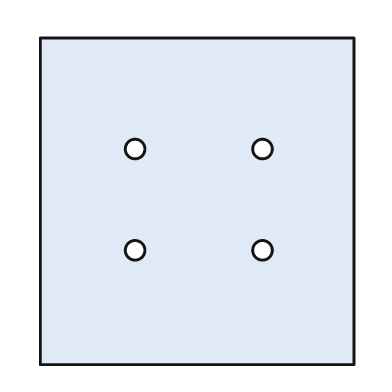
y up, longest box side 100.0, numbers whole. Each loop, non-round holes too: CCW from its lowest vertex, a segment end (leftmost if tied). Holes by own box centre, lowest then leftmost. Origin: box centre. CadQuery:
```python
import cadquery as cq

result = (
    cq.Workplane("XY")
    .moveTo(-48.0, -50.0)
    .lineTo(48.0, -50.0)
    .lineTo(48.0, 50.0)
    .lineTo(-48.0, 50.0)
    .close()
    .moveTo(-19.0, -15.0)
    .circle(3.0)
    .moveTo(20.0, -15.0)
    .circle(3.0)
    .moveTo(-19.0, 16.0)
    .circle(3.0)
    .moveTo(20.0, 16.0)
    .circle(3.0)
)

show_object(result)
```